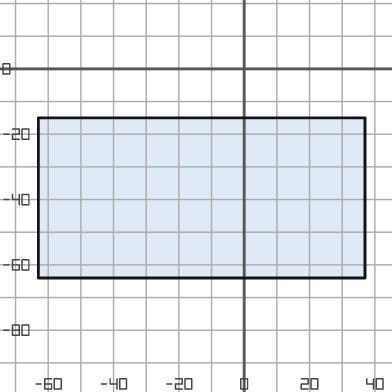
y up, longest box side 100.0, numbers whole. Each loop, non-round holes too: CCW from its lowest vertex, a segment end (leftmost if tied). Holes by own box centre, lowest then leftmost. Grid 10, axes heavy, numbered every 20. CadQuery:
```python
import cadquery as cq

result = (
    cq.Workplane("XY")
    .moveTo(-63.0, -64.0)
    .lineTo(37.0, -64.0)
    .lineTo(37.0, -15.0)
    .lineTo(-63.0, -15.0)
    .close()
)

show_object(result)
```